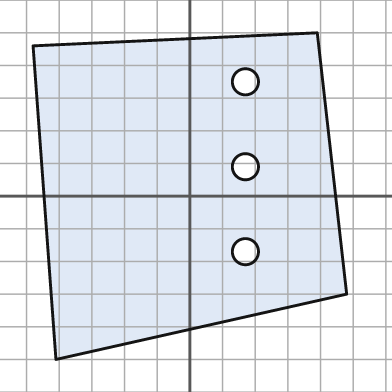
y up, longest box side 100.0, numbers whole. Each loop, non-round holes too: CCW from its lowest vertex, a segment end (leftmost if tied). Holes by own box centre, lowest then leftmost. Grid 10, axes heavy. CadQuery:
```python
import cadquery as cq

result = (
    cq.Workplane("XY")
    .moveTo(-41.0, -50.0)
    .lineTo(48.0, -30.0)
    .lineTo(39.0, 50.0)
    .lineTo(-48.0, 46.0)
    .close()
    .moveTo(17.0, -17.0)
    .circle(4.0)
    .moveTo(17.0, 9.0)
    .circle(4.0)
    .moveTo(17.0, 35.0)
    .circle(4.0)
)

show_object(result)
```